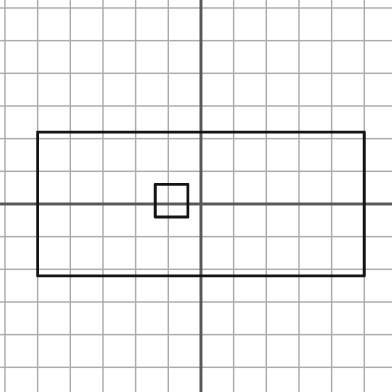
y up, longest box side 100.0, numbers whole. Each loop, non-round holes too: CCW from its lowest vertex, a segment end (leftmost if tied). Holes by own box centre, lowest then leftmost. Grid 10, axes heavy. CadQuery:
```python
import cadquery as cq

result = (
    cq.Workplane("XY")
    .moveTo(-50.0, -22.0)
    .lineTo(50.0, -22.0)
    .lineTo(50.0, 22.0)
    .lineTo(-50.0, 22.0)
    .close()
    .moveTo(-14.0, -4.0)
    .lineTo(-4.0, -4.0)
    .lineTo(-4.0, 6.0)
    .lineTo(-14.0, 6.0)
    .close()
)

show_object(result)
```